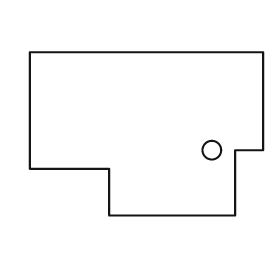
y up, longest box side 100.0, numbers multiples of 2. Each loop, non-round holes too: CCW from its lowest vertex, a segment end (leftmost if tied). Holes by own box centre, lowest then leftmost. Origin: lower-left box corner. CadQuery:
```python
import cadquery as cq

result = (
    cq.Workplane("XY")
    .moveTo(34.0, 0.0)
    .lineTo(88.0, 0.0)
    .lineTo(88.0, 28.0)
    .lineTo(100.0, 28.0)
    .lineTo(100.0, 70.0)
    .lineTo(0.0, 70.0)
    .lineTo(0.0, 20.0)
    .lineTo(34.0, 20.0)
    .close()
    .moveTo(78.0, 28.0)
    .circle(4.0)
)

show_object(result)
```